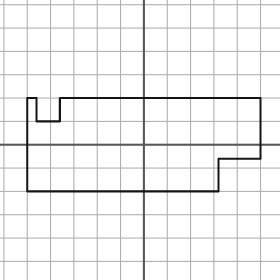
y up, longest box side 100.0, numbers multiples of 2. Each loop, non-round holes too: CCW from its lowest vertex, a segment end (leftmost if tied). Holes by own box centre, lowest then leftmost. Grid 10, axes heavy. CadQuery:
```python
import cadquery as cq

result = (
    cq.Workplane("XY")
    .moveTo(-50.0, -20.0)
    .lineTo(32.0, -20.0)
    .lineTo(32.0, -6.0)
    .lineTo(50.0, -6.0)
    .lineTo(50.0, 20.0)
    .lineTo(-36.0, 20.0)
    .lineTo(-36.0, 10.0)
    .lineTo(-46.0, 10.0)
    .lineTo(-46.0, 20.0)
    .lineTo(-50.0, 20.0)
    .close()
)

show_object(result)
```